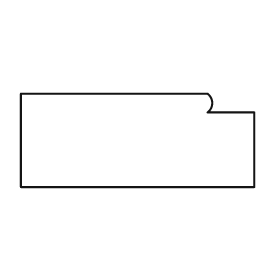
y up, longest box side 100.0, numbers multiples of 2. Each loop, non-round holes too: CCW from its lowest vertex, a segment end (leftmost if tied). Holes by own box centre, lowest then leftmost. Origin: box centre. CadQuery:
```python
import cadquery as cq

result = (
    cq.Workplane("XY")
    .moveTo(-50.0, -20.0)
    .lineTo(50.0, -20.0)
    .lineTo(50.0, 12.0)
    .lineTo(30.0, 12.0)
    .threePointArc((32.0, 16.0), (30.0, 20.0))
    .lineTo(-50.0, 20.0)
    .close()
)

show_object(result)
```